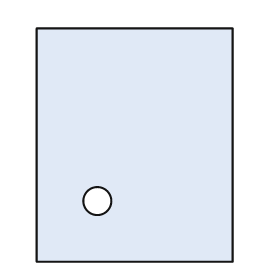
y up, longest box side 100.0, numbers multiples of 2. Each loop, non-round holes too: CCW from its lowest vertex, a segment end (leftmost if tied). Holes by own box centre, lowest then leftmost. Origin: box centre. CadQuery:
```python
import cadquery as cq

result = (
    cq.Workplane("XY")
    .moveTo(-42.0, -50.0)
    .lineTo(42.0, -50.0)
    .lineTo(42.0, 50.0)
    .lineTo(-42.0, 50.0)
    .close()
    .moveTo(-16.0, -24.0)
    .circle(6.0)
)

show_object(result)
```